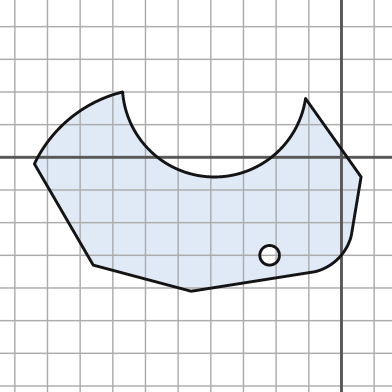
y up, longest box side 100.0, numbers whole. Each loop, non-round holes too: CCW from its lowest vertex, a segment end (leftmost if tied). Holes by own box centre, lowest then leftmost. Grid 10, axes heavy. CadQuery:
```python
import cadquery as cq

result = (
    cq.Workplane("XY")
    .moveTo(-46.0, -41.0)
    .lineTo(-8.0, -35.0)
    .threePointArc((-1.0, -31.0), (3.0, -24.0))
    .lineTo(6.0, -6.0)
    .lineTo(-11.0, 18.0)
    .threePointArc((-40.0, -6.0), (-67.0, 20.0))
    .threePointArc((-83.0, 12.0), (-94.0, -2.0))
    .lineTo(-76.0, -33.0)
    .close()
    .moveTo(-22.0, -30.0)
    .circle(3.0)
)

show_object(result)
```